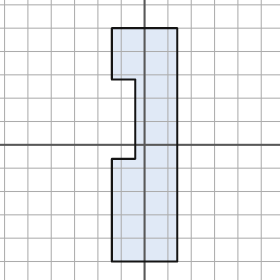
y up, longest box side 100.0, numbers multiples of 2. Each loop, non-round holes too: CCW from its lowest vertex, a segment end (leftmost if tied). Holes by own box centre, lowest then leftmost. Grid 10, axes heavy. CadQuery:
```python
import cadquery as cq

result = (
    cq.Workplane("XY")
    .moveTo(-14.0, -50.0)
    .lineTo(14.0, -50.0)
    .lineTo(14.0, 50.0)
    .lineTo(-14.0, 50.0)
    .lineTo(-14.0, 28.0)
    .lineTo(-4.0, 28.0)
    .lineTo(-4.0, -6.0)
    .lineTo(-14.0, -6.0)
    .close()
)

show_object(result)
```